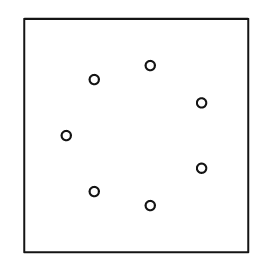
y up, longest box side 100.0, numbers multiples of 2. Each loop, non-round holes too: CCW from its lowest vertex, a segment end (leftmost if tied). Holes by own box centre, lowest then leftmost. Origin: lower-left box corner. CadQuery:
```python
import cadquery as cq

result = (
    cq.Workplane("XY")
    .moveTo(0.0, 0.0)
    .lineTo(96.0, 0.0)
    .lineTo(96.0, 100.0)
    .lineTo(0.0, 100.0)
    .close()
    .moveTo(54.0, 20.0)
    .circle(2.0)
    .moveTo(30.0, 26.0)
    .circle(2.0)
    .moveTo(76.0, 36.0)
    .circle(2.0)
    .moveTo(18.0, 50.0)
    .circle(2.0)
    .moveTo(76.0, 64.0)
    .circle(2.0)
    .moveTo(30.0, 74.0)
    .circle(2.0)
    .moveTo(54.0, 80.0)
    .circle(2.0)
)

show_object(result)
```